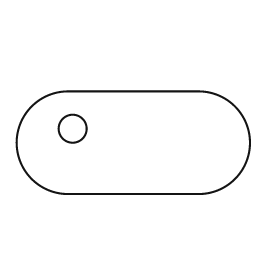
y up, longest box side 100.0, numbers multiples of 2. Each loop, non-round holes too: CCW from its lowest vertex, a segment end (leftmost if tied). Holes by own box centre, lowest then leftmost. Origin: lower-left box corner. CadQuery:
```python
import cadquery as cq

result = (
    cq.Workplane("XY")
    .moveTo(22.0, 0.0)
    .lineTo(78.0, 0.0)
    .threePointArc((100.0, 22.0), (78.0, 44.0))
    .lineTo(22.0, 44.0)
    .threePointArc((0.0, 22.0), (22.0, 0.0))
    .close()
    .moveTo(24.0, 28.0)
    .circle(6.0)
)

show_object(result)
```